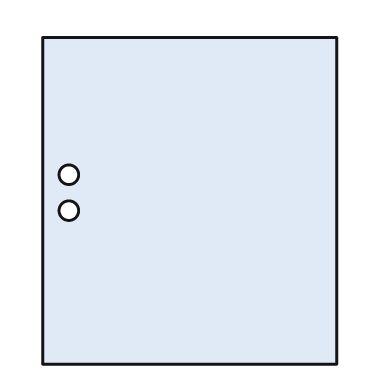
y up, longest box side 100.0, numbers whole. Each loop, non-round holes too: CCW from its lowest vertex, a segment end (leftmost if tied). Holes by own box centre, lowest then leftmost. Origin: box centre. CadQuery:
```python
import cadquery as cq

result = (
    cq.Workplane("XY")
    .moveTo(-45.0, -50.0)
    .lineTo(45.0, -50.0)
    .lineTo(45.0, 50.0)
    .lineTo(-45.0, 50.0)
    .close()
    .moveTo(-37.0, -3.0)
    .circle(3.0)
    .moveTo(-37.0, 8.0)
    .circle(3.0)
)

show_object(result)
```